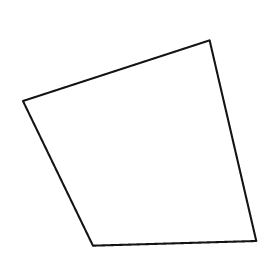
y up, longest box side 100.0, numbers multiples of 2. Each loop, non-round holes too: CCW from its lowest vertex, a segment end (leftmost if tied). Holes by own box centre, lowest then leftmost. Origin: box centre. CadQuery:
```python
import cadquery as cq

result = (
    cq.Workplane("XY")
    .moveTo(-20.0, -44.0)
    .lineTo(50.0, -42.0)
    .lineTo(30.0, 44.0)
    .lineTo(-50.0, 18.0)
    .close()
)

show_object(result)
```